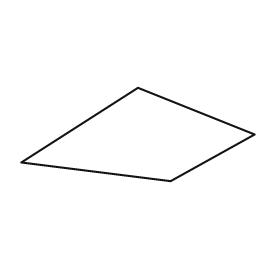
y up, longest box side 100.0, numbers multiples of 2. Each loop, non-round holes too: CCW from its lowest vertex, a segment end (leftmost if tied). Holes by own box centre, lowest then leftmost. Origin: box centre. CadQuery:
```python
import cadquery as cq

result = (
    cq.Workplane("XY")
    .moveTo(14.0, -20.0)
    .lineTo(50.0, 0.0)
    .lineTo(0.0, 20.0)
    .lineTo(-50.0, -12.0)
    .close()
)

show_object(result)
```